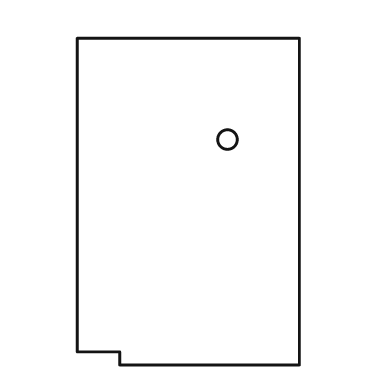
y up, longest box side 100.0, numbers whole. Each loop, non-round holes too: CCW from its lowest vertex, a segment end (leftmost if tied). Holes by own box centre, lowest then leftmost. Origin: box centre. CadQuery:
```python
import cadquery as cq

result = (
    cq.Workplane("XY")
    .moveTo(-21.0, -50.0)
    .lineTo(34.0, -50.0)
    .lineTo(34.0, 50.0)
    .lineTo(-34.0, 50.0)
    .lineTo(-34.0, -46.0)
    .lineTo(-21.0, -46.0)
    .close()
    .moveTo(12.0, 19.0)
    .circle(3.0)
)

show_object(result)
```